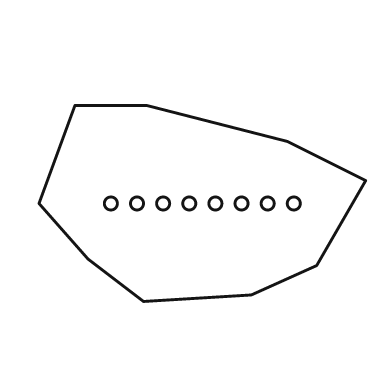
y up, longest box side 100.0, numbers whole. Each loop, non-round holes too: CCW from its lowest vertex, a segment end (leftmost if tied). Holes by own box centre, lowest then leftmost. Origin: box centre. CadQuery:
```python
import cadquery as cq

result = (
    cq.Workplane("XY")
    .moveTo(-18.0, -30.0)
    .lineTo(15.0, -28.0)
    .lineTo(35.0, -19.0)
    .lineTo(50.0, 7.0)
    .lineTo(26.0, 19.0)
    .lineTo(-17.0, 30.0)
    .lineTo(-39.0, 30.0)
    .lineTo(-50.0, 0.0)
    .lineTo(-35.0, -17.0)
    .close()
    .moveTo(-28.0, 0.0)
    .circle(2.0)
    .moveTo(-20.0, 0.0)
    .circle(2.0)
    .moveTo(-12.0, 0.0)
    .circle(2.0)
    .moveTo(-4.0, 0.0)
    .circle(2.0)
    .moveTo(4.0, 0.0)
    .circle(2.0)
    .moveTo(12.0, 0.0)
    .circle(2.0)
    .moveTo(20.0, 0.0)
    .circle(2.0)
    .moveTo(28.0, 0.0)
    .circle(2.0)
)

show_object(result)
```